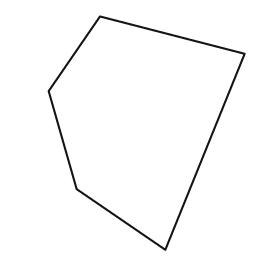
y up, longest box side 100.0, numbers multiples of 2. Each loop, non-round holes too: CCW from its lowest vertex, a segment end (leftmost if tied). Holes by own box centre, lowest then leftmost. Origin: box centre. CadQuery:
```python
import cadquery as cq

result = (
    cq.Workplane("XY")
    .moveTo(8.0, -50.0)
    .lineTo(42.0, 34.0)
    .lineTo(-20.0, 50.0)
    .lineTo(-42.0, 18.0)
    .lineTo(-30.0, -24.0)
    .close()
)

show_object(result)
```